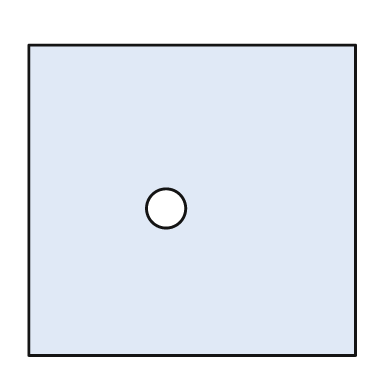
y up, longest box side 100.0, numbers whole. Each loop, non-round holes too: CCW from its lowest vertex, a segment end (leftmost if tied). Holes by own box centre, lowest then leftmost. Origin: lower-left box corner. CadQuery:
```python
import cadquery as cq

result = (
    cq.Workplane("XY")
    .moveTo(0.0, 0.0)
    .lineTo(100.0, 0.0)
    .lineTo(100.0, 95.0)
    .lineTo(0.0, 95.0)
    .close()
    .moveTo(42.0, 45.0)
    .circle(6.0)
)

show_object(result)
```